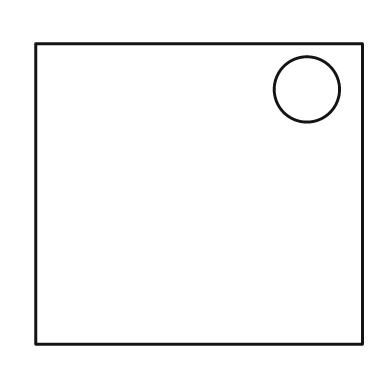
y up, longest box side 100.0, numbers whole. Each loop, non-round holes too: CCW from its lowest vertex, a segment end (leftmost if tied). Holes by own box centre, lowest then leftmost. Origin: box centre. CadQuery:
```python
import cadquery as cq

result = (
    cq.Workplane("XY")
    .moveTo(-50.0, -46.0)
    .lineTo(50.0, -46.0)
    .lineTo(50.0, 46.0)
    .lineTo(-50.0, 46.0)
    .close()
    .moveTo(33.0, 32.0)
    .circle(10.0)
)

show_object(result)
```